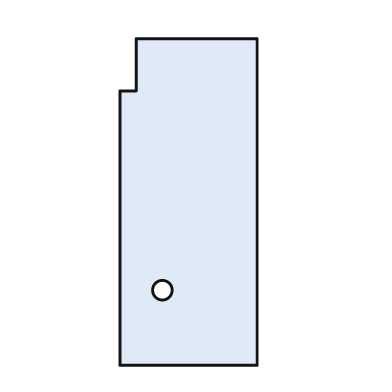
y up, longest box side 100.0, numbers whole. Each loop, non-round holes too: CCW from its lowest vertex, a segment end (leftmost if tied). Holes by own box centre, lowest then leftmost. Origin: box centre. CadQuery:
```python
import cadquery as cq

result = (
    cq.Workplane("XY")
    .moveTo(-21.0, -50.0)
    .lineTo(21.0, -50.0)
    .lineTo(21.0, 50.0)
    .lineTo(-16.0, 50.0)
    .lineTo(-16.0, 34.0)
    .lineTo(-21.0, 34.0)
    .close()
    .moveTo(-8.0, -27.0)
    .circle(3.0)
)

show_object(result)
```